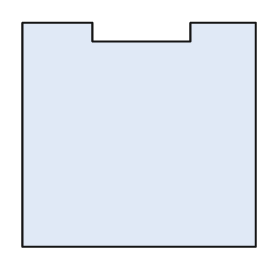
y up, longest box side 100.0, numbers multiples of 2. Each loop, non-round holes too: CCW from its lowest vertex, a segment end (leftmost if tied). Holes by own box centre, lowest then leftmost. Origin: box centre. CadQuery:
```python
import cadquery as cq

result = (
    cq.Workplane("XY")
    .moveTo(-50.0, -48.0)
    .lineTo(50.0, -48.0)
    .lineTo(50.0, 48.0)
    .lineTo(22.0, 48.0)
    .lineTo(22.0, 40.0)
    .lineTo(-20.0, 40.0)
    .lineTo(-20.0, 48.0)
    .lineTo(-50.0, 48.0)
    .close()
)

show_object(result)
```